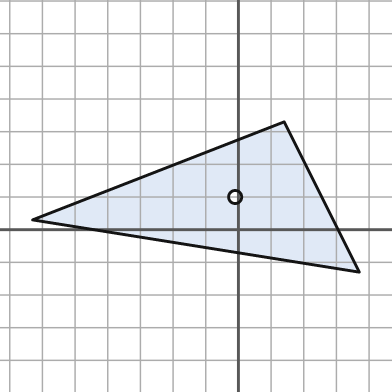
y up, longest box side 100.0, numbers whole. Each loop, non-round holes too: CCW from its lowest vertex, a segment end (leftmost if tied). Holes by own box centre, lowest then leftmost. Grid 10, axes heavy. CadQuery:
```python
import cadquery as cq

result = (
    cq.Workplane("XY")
    .moveTo(37.0, -13.0)
    .lineTo(14.0, 33.0)
    .lineTo(-63.0, 3.0)
    .close()
    .moveTo(-1.0, 10.0)
    .circle(2.0)
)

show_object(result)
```